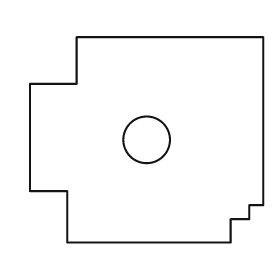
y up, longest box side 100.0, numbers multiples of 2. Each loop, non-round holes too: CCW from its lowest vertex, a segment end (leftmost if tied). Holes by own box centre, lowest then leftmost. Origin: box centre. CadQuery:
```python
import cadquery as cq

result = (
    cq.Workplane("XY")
    .moveTo(-34.0, -44.0)
    .lineTo(36.0, -44.0)
    .lineTo(36.0, -34.0)
    .lineTo(44.0, -34.0)
    .lineTo(44.0, -28.0)
    .lineTo(50.0, -28.0)
    .lineTo(50.0, 44.0)
    .lineTo(-30.0, 44.0)
    .lineTo(-30.0, 24.0)
    .lineTo(-50.0, 24.0)
    .lineTo(-50.0, -22.0)
    .lineTo(-34.0, -22.0)
    .close()
    .moveTo(0.0, 0.0)
    .circle(10.0)
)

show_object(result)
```